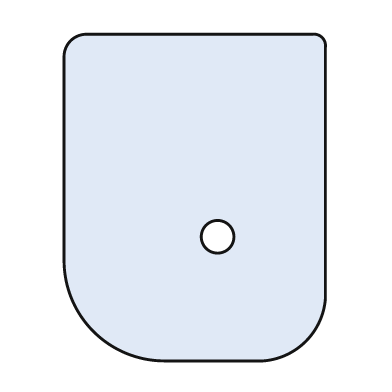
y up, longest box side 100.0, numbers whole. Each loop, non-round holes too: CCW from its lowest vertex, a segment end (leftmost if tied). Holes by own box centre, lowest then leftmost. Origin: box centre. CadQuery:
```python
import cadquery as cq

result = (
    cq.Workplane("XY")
    .moveTo(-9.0, -50.0)
    .lineTo(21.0, -50.0)
    .threePointArc((34.0, -44.0), (40.0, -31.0))
    .lineTo(40.0, 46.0)
    .threePointArc((39.0, 49.0), (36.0, 50.0))
    .lineTo(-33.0, 50.0)
    .threePointArc((-38.0, 48.0), (-40.0, 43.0))
    .lineTo(-40.0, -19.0)
    .threePointArc((-31.0, -41.0), (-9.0, -50.0))
    .close()
    .moveTo(7.0, -12.0)
    .circle(5.0)
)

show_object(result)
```